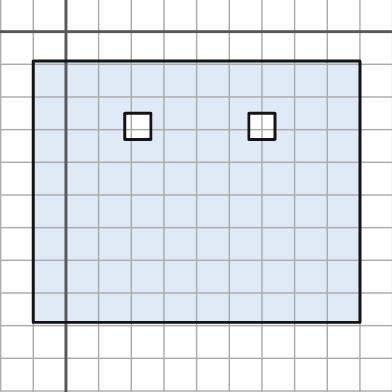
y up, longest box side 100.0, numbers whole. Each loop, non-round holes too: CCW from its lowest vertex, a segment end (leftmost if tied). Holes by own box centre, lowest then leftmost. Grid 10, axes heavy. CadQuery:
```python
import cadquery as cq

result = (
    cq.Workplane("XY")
    .moveTo(-10.0, -89.0)
    .lineTo(90.0, -89.0)
    .lineTo(90.0, -9.0)
    .lineTo(-10.0, -9.0)
    .close()
    .moveTo(18.0, -33.0)
    .lineTo(26.0, -33.0)
    .lineTo(26.0, -25.0)
    .lineTo(18.0, -25.0)
    .close()
    .moveTo(56.0, -33.0)
    .lineTo(64.0, -33.0)
    .lineTo(64.0, -25.0)
    .lineTo(56.0, -25.0)
    .close()
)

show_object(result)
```